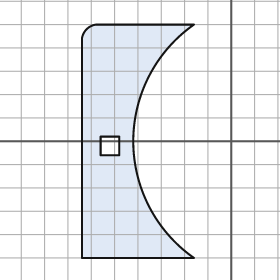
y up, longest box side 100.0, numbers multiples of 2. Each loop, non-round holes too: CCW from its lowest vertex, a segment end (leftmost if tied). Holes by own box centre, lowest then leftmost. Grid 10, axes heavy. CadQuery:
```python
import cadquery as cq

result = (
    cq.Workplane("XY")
    .moveTo(-64.0, -50.0)
    .lineTo(-16.0, -50.0)
    .threePointArc((-42.0, 0.0), (-16.0, 50.0))
    .lineTo(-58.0, 50.0)
    .threePointArc((-62.0, 48.0), (-64.0, 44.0))
    .close()
    .moveTo(-56.0, -6.0)
    .lineTo(-48.0, -6.0)
    .lineTo(-48.0, 2.0)
    .lineTo(-56.0, 2.0)
    .close()
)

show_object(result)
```